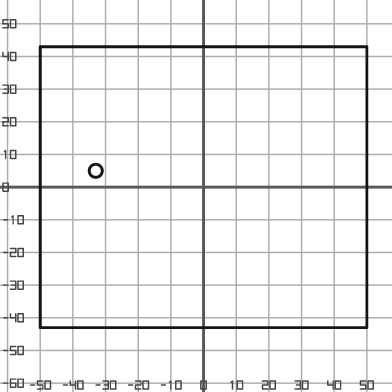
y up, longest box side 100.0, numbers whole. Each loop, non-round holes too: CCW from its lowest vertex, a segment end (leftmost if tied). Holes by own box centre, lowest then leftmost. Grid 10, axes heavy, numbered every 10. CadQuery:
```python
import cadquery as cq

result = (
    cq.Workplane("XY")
    .moveTo(-50.0, -43.0)
    .lineTo(50.0, -43.0)
    .lineTo(50.0, 43.0)
    .lineTo(-50.0, 43.0)
    .close()
    .moveTo(-33.0, 5.0)
    .circle(2.0)
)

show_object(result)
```